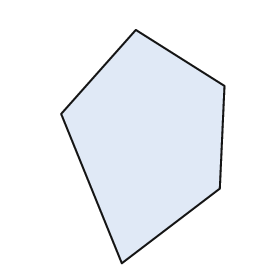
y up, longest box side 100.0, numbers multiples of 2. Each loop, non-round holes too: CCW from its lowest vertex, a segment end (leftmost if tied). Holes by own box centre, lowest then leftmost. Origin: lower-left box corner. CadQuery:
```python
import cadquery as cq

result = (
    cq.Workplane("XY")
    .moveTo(26.0, 0.0)
    .lineTo(68.0, 32.0)
    .lineTo(70.0, 76.0)
    .lineTo(32.0, 100.0)
    .lineTo(0.0, 64.0)
    .close()
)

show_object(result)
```